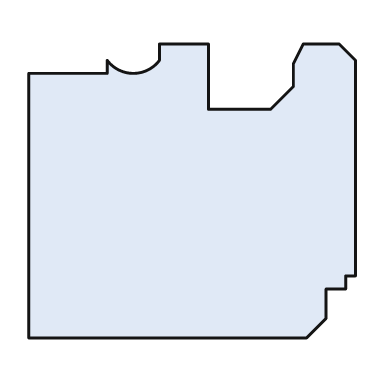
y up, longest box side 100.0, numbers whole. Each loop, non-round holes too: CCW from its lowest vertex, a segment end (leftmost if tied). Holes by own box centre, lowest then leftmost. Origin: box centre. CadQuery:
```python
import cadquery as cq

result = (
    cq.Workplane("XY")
    .moveTo(-50.0, -45.0)
    .lineTo(35.0, -45.0)
    .lineTo(41.0, -39.0)
    .lineTo(41.0, -30.0)
    .lineTo(47.0, -30.0)
    .lineTo(47.0, -26.0)
    .lineTo(50.0, -26.0)
    .lineTo(50.0, 40.0)
    .lineTo(45.0, 45.0)
    .lineTo(34.0, 45.0)
    .lineTo(31.0, 39.0)
    .lineTo(31.0, 32.0)
    .lineTo(24.0, 25.0)
    .lineTo(5.0, 25.0)
    .lineTo(5.0, 45.0)
    .lineTo(-10.0, 45.0)
    .lineTo(-10.0, 40.0)
    .threePointArc((-18.0, 36.0), (-26.0, 40.0))
    .lineTo(-26.0, 36.0)
    .lineTo(-50.0, 36.0)
    .close()
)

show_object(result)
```